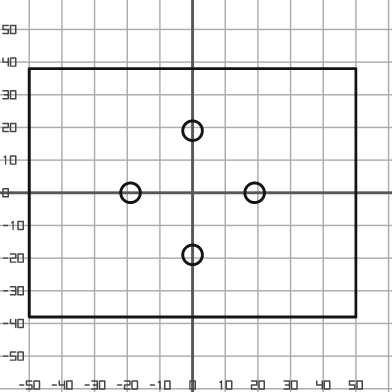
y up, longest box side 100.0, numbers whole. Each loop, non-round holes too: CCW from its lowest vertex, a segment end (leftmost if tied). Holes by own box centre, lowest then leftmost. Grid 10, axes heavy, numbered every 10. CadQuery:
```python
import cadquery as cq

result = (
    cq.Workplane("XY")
    .moveTo(-50.0, -38.0)
    .lineTo(50.0, -38.0)
    .lineTo(50.0, 38.0)
    .lineTo(-50.0, 38.0)
    .close()
    .moveTo(0.0, -19.0)
    .circle(3.0)
    .moveTo(-19.0, 0.0)
    .circle(3.0)
    .moveTo(19.0, 0.0)
    .circle(3.0)
    .moveTo(0.0, 19.0)
    .circle(3.0)
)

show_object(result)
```